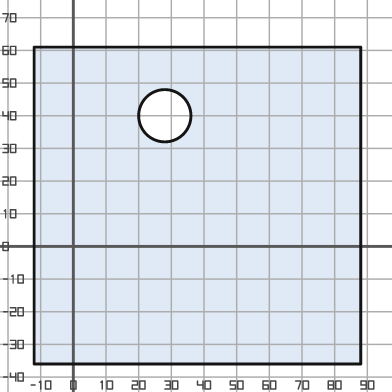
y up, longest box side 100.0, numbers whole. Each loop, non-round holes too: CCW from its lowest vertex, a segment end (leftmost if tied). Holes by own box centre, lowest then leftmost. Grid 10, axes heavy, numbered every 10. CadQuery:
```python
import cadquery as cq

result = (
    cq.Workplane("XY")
    .moveTo(-12.0, -36.0)
    .lineTo(88.0, -36.0)
    .lineTo(88.0, 61.0)
    .lineTo(-12.0, 61.0)
    .close()
    .moveTo(28.0, 40.0)
    .circle(8.0)
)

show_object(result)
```